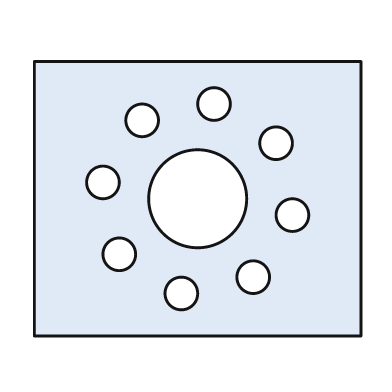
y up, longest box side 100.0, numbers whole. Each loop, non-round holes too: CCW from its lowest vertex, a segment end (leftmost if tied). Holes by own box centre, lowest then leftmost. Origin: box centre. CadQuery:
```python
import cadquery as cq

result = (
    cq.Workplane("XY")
    .moveTo(-50.0, -42.0)
    .lineTo(50.0, -42.0)
    .lineTo(50.0, 42.0)
    .lineTo(-50.0, 42.0)
    .close()
    .moveTo(-5.0, -29.0)
    .circle(5.0)
    .moveTo(17.0, -24.0)
    .circle(5.0)
    .moveTo(-24.0, -17.0)
    .circle(5.0)
    .moveTo(29.0, -5.0)
    .circle(5.0)
    .moveTo(0.0, 0.0)
    .circle(15.0)
    .moveTo(-29.0, 5.0)
    .circle(5.0)
    .moveTo(24.0, 17.0)
    .circle(5.0)
    .moveTo(-17.0, 24.0)
    .circle(5.0)
    .moveTo(5.0, 29.0)
    .circle(5.0)
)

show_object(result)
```